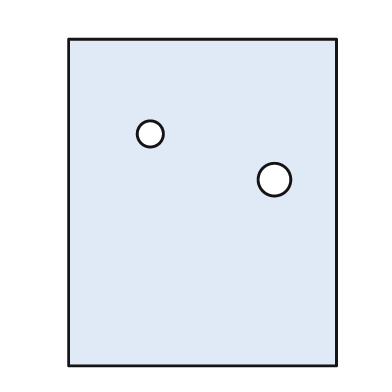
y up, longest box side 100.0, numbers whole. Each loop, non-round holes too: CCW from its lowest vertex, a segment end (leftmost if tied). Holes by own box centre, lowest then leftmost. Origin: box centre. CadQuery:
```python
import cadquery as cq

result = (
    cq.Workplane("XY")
    .moveTo(-41.0, -50.0)
    .lineTo(41.0, -50.0)
    .lineTo(41.0, 50.0)
    .lineTo(-41.0, 50.0)
    .close()
    .moveTo(22.0, 7.0)
    .circle(5.0)
    .moveTo(-16.0, 21.0)
    .circle(4.0)
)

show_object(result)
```